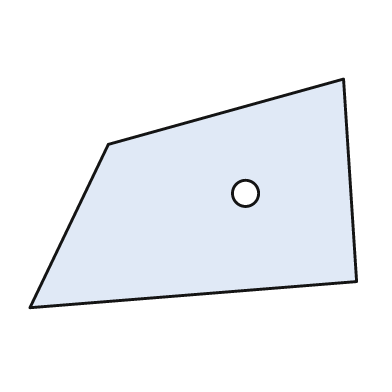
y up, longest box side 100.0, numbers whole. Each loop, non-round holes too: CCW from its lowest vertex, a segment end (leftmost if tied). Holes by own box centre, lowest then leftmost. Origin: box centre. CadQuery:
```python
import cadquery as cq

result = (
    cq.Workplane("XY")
    .moveTo(-50.0, -35.0)
    .lineTo(50.0, -27.0)
    .lineTo(46.0, 35.0)
    .lineTo(-26.0, 15.0)
    .close()
    .moveTo(16.0, 0.0)
    .circle(4.0)
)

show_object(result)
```